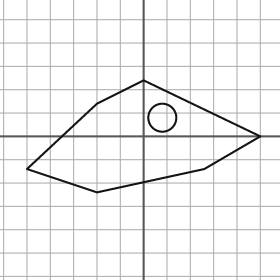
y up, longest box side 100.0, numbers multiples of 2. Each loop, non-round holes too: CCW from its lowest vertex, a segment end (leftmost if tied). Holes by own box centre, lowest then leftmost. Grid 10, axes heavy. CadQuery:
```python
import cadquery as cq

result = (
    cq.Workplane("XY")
    .moveTo(-20.0, -24.0)
    .lineTo(26.0, -14.0)
    .lineTo(50.0, 0.0)
    .lineTo(0.0, 24.0)
    .lineTo(-20.0, 14.0)
    .lineTo(-50.0, -14.0)
    .close()
    .moveTo(8.0, 8.0)
    .circle(6.0)
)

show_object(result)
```